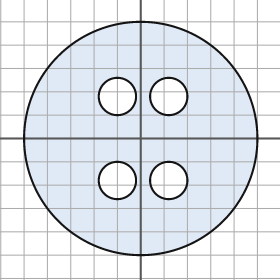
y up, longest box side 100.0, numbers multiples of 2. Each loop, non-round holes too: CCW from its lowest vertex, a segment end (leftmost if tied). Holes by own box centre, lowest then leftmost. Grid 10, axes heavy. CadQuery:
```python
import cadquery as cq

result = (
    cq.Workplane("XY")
    .moveTo(0.0, 0.0)
    .circle(50.0)
    .moveTo(-10.0, -18.0)
    .circle(8.0)
    .moveTo(12.0, -18.0)
    .circle(8.0)
    .moveTo(-10.0, 18.0)
    .circle(8.0)
    .moveTo(12.0, 18.0)
    .circle(8.0)
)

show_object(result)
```